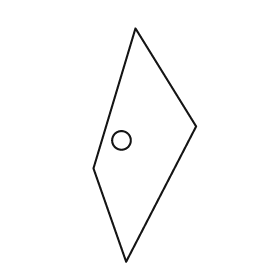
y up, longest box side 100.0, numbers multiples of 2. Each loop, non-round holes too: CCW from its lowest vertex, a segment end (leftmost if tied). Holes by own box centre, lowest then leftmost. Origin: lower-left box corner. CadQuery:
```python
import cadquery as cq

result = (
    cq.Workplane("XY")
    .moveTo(14.0, 0.0)
    .lineTo(44.0, 58.0)
    .lineTo(18.0, 100.0)
    .lineTo(0.0, 40.0)
    .close()
    .moveTo(12.0, 52.0)
    .circle(4.0)
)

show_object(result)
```